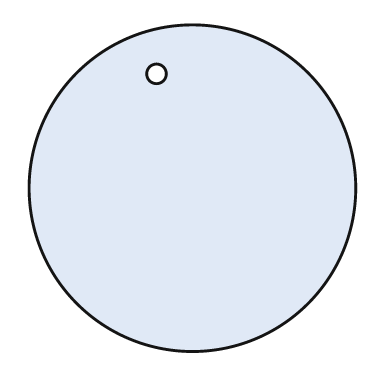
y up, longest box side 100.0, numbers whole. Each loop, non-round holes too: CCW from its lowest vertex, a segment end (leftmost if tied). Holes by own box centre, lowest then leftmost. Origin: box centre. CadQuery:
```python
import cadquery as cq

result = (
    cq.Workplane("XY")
    .moveTo(0.0, 0.0)
    .circle(50.0)
    .moveTo(-11.0, 35.0)
    .circle(3.0)
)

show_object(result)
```